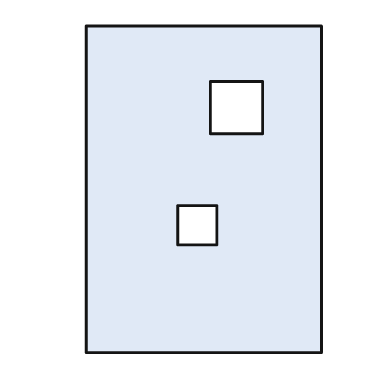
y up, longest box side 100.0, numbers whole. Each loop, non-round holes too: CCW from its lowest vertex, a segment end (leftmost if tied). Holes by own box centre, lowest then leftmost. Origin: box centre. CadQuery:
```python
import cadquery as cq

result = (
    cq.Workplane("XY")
    .moveTo(-36.0, -50.0)
    .lineTo(36.0, -50.0)
    .lineTo(36.0, 50.0)
    .lineTo(-36.0, 50.0)
    .close()
    .moveTo(-8.0, -17.0)
    .lineTo(4.0, -17.0)
    .lineTo(4.0, -5.0)
    .lineTo(-8.0, -5.0)
    .close()
    .moveTo(2.0, 17.0)
    .lineTo(18.0, 17.0)
    .lineTo(18.0, 33.0)
    .lineTo(2.0, 33.0)
    .close()
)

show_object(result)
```